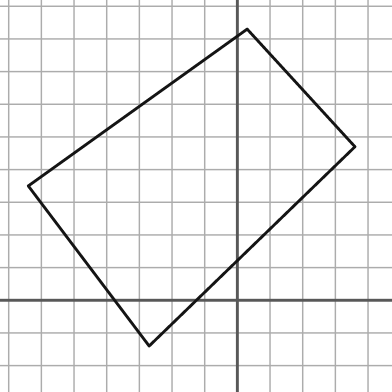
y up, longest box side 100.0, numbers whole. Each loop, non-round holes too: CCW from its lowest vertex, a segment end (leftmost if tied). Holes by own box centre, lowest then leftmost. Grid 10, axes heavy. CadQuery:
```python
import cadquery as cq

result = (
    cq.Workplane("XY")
    .moveTo(-27.0, -14.0)
    .lineTo(36.0, 47.0)
    .lineTo(3.0, 83.0)
    .lineTo(-64.0, 35.0)
    .close()
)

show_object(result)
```